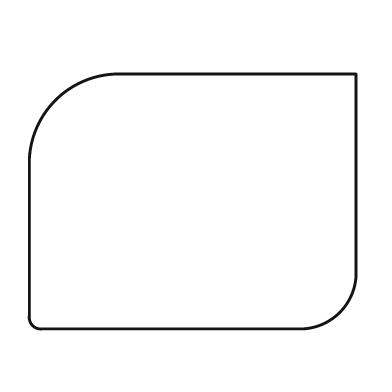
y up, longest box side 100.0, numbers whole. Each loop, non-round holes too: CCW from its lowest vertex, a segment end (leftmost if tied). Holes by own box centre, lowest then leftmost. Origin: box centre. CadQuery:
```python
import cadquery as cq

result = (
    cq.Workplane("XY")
    .moveTo(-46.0, -39.0)
    .lineTo(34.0, -39.0)
    .threePointArc((45.0, -34.0), (50.0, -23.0))
    .lineTo(50.0, 39.0)
    .lineTo(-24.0, 39.0)
    .threePointArc((-42.0, 31.0), (-50.0, 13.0))
    .lineTo(-50.0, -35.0)
    .threePointArc((-49.0, -38.0), (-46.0, -39.0))
    .close()
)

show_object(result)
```